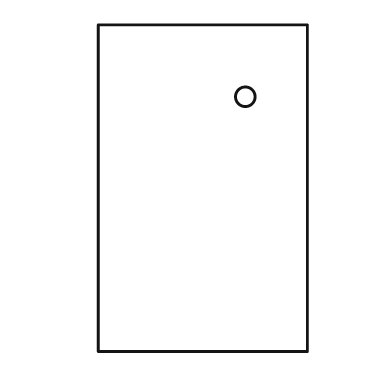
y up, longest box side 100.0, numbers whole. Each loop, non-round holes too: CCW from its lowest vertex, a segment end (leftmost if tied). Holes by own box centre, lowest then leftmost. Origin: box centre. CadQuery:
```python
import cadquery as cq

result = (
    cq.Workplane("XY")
    .moveTo(-32.0, -50.0)
    .lineTo(32.0, -50.0)
    .lineTo(32.0, 50.0)
    .lineTo(-32.0, 50.0)
    .close()
    .moveTo(13.0, 28.0)
    .circle(3.0)
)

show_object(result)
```